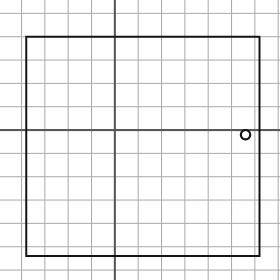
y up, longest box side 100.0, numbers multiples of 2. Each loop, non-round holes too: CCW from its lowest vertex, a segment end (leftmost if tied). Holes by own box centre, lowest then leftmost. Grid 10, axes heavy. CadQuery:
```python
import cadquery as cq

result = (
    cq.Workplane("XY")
    .moveTo(-38.0, -54.0)
    .lineTo(62.0, -54.0)
    .lineTo(62.0, 40.0)
    .lineTo(-38.0, 40.0)
    .close()
    .moveTo(56.0, -2.0)
    .circle(2.0)
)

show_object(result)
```